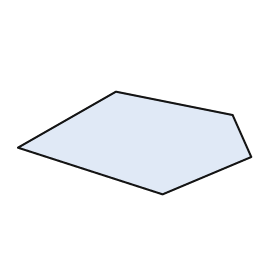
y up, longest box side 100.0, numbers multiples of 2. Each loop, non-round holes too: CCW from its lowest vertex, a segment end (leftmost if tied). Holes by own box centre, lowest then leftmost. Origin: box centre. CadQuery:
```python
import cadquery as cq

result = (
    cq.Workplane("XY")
    .moveTo(12.0, -22.0)
    .lineTo(50.0, -6.0)
    .lineTo(42.0, 12.0)
    .lineTo(-8.0, 22.0)
    .lineTo(-50.0, -2.0)
    .close()
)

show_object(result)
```